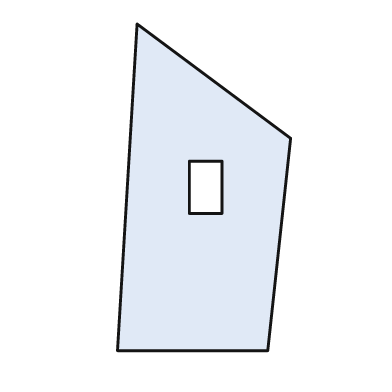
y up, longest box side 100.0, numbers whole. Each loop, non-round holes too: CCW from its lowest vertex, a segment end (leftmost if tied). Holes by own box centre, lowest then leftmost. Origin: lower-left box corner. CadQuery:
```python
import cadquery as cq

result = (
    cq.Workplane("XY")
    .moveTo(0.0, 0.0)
    .lineTo(46.0, 0.0)
    .lineTo(53.0, 65.0)
    .lineTo(6.0, 100.0)
    .close()
    .moveTo(22.0, 42.0)
    .lineTo(32.0, 42.0)
    .lineTo(32.0, 58.0)
    .lineTo(22.0, 58.0)
    .close()
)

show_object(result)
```